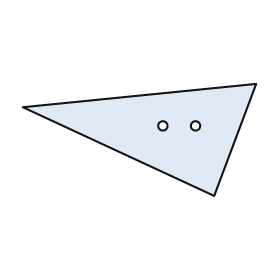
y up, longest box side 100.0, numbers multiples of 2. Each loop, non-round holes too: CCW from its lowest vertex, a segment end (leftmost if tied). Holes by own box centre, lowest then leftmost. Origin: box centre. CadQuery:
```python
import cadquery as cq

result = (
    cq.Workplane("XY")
    .moveTo(32.0, -24.0)
    .lineTo(50.0, 24.0)
    .lineTo(-50.0, 14.0)
    .close()
    .moveTo(10.0, 6.0)
    .circle(2.0)
    .moveTo(24.0, 6.0)
    .circle(2.0)
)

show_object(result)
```